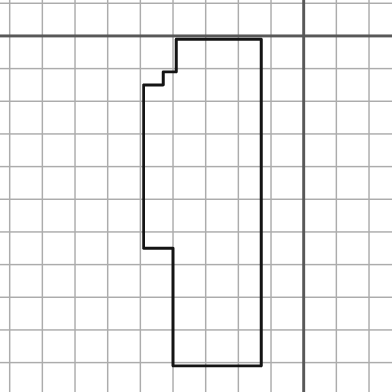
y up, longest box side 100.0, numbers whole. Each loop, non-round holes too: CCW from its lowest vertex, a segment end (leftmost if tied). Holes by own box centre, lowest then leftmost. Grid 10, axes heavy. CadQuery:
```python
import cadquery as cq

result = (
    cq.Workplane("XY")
    .moveTo(-40.0, -101.0)
    .lineTo(-13.0, -101.0)
    .lineTo(-13.0, -1.0)
    .lineTo(-39.0, -1.0)
    .lineTo(-39.0, -11.0)
    .lineTo(-43.0, -11.0)
    .lineTo(-43.0, -15.0)
    .lineTo(-49.0, -15.0)
    .lineTo(-49.0, -65.0)
    .lineTo(-40.0, -65.0)
    .close()
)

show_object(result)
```